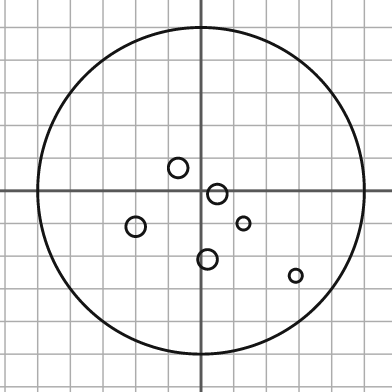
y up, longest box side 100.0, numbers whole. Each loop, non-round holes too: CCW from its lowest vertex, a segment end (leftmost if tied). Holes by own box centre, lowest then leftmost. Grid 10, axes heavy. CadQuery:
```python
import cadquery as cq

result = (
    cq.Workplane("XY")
    .moveTo(0.0, 0.0)
    .circle(50.0)
    .moveTo(29.0, -26.0)
    .circle(2.0)
    .moveTo(2.0, -21.0)
    .circle(3.0)
    .moveTo(-20.0, -11.0)
    .circle(3.0)
    .moveTo(13.0, -10.0)
    .circle(2.0)
    .moveTo(5.0, -1.0)
    .circle(3.0)
    .moveTo(-7.0, 7.0)
    .circle(3.0)
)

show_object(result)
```